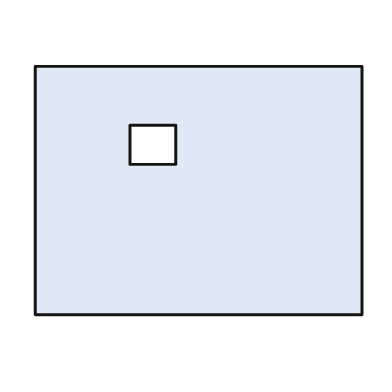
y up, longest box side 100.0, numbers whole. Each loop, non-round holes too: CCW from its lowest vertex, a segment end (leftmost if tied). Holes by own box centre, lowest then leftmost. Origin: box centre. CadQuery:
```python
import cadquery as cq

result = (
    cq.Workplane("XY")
    .moveTo(-50.0, -38.0)
    .lineTo(50.0, -38.0)
    .lineTo(50.0, 38.0)
    .lineTo(-50.0, 38.0)
    .close()
    .moveTo(-21.0, 8.0)
    .lineTo(-7.0, 8.0)
    .lineTo(-7.0, 20.0)
    .lineTo(-21.0, 20.0)
    .close()
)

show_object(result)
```